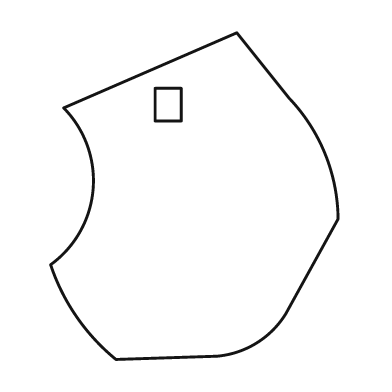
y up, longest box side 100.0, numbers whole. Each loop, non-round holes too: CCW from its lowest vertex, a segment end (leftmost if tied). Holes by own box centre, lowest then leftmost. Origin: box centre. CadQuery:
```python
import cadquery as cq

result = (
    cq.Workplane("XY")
    .moveTo(-24.0, -50.0)
    .lineTo(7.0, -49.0)
    .threePointArc((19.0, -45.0), (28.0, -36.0))
    .lineTo(44.0, -7.0)
    .threePointArc((40.0, 13.0), (29.0, 30.0))
    .lineTo(13.0, 50.0)
    .lineTo(-40.0, 27.0)
    .threePointArc((-31.0, 2.0), (-44.0, -21.0))
    .threePointArc((-36.0, -37.0), (-24.0, -50.0))
    .close()
    .moveTo(-12.0, 23.0)
    .lineTo(-4.0, 23.0)
    .lineTo(-4.0, 33.0)
    .lineTo(-12.0, 33.0)
    .close()
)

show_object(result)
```